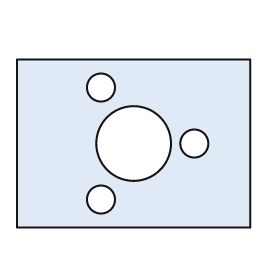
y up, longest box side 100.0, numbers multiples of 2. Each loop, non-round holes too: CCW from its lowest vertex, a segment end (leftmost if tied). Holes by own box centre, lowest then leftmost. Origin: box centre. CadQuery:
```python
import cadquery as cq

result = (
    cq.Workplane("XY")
    .moveTo(-50.0, -36.0)
    .lineTo(50.0, -36.0)
    .lineTo(50.0, 36.0)
    .lineTo(-50.0, 36.0)
    .close()
    .moveTo(-14.0, -24.0)
    .circle(6.0)
    .moveTo(0.0, 0.0)
    .circle(16.0)
    .moveTo(26.0, 0.0)
    .circle(6.0)
    .moveTo(-14.0, 24.0)
    .circle(6.0)
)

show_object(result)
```